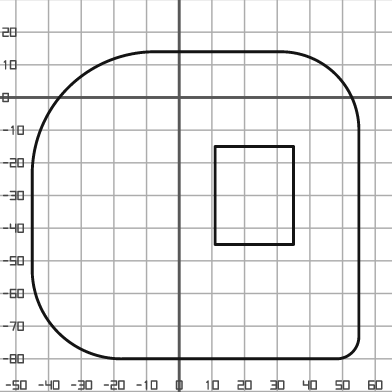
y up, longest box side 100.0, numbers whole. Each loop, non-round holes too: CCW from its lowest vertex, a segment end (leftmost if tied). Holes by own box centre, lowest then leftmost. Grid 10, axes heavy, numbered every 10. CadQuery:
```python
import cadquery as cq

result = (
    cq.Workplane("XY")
    .moveTo(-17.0, -80.0)
    .lineTo(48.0, -80.0)
    .threePointArc((53.0, -78.0), (55.0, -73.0))
    .lineTo(55.0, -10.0)
    .threePointArc((48.0, 7.0), (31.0, 14.0))
    .lineTo(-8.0, 14.0)
    .threePointArc((-34.0, 3.0), (-45.0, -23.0))
    .lineTo(-45.0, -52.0)
    .threePointArc((-37.0, -72.0), (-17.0, -80.0))
    .close()
    .moveTo(11.0, -45.0)
    .lineTo(35.0, -45.0)
    .lineTo(35.0, -15.0)
    .lineTo(11.0, -15.0)
    .close()
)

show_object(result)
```